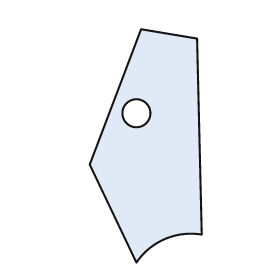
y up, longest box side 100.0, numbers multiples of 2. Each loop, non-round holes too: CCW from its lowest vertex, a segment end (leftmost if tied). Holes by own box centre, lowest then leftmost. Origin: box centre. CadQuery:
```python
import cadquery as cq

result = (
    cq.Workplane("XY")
    .moveTo(-4.0, -50.0)
    .threePointArc((8.0, -40.0), (24.0, -38.0))
    .lineTo(22.0, 46.0)
    .lineTo(-2.0, 50.0)
    .lineTo(-24.0, -8.0)
    .close()
    .moveTo(-4.0, 14.0)
    .circle(6.0)
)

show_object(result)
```